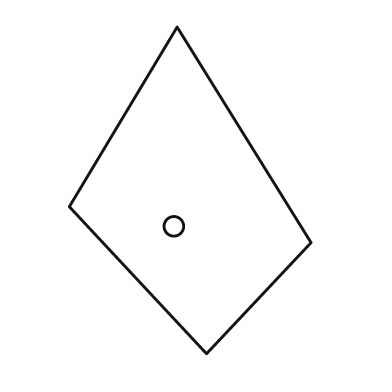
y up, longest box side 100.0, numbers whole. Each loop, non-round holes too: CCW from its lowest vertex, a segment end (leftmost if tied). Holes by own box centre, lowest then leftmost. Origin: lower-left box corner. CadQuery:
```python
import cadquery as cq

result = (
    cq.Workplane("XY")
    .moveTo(42.0, 0.0)
    .lineTo(74.0, 34.0)
    .lineTo(33.0, 100.0)
    .lineTo(0.0, 45.0)
    .close()
    .moveTo(32.0, 39.0)
    .circle(3.0)
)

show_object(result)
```